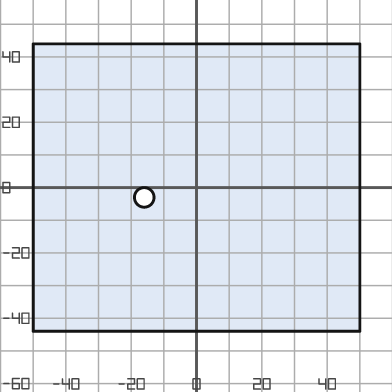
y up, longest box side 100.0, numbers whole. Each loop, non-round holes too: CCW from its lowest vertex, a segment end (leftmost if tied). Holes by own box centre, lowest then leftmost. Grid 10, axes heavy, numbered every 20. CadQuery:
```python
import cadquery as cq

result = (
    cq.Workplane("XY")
    .moveTo(-50.0, -44.0)
    .lineTo(50.0, -44.0)
    .lineTo(50.0, 44.0)
    .lineTo(-50.0, 44.0)
    .close()
    .moveTo(-16.0, -3.0)
    .circle(3.0)
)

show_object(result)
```